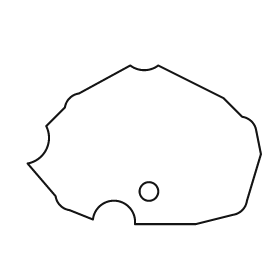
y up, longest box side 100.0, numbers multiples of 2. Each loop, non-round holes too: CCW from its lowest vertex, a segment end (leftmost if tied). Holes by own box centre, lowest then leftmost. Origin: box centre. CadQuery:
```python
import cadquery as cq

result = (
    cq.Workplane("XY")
    .moveTo(-4.0, -34.0)
    .lineTo(22.0, -34.0)
    .lineTo(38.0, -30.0)
    .threePointArc((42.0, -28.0), (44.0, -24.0))
    .lineTo(50.0, -4.0)
    .lineTo(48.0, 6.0)
    .threePointArc((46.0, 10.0), (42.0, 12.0))
    .lineTo(34.0, 20.0)
    .lineTo(6.0, 34.0)
    .threePointArc((0.0, 32.0), (-6.0, 34.0))
    .lineTo(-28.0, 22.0)
    .threePointArc((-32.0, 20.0), (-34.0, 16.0))
    .lineTo(-42.0, 8.0)
    .threePointArc((-42.0, -2.0), (-50.0, -8.0))
    .lineTo(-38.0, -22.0)
    .threePointArc((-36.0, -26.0), (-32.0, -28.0))
    .lineTo(-22.0, -32.0)
    .threePointArc((-12.0, -24.0), (-4.0, -34.0))
    .close()
    .moveTo(2.0, -20.0)
    .circle(4.0)
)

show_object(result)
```